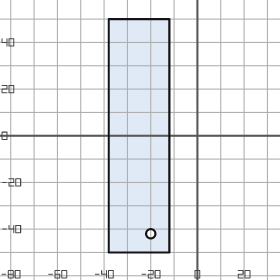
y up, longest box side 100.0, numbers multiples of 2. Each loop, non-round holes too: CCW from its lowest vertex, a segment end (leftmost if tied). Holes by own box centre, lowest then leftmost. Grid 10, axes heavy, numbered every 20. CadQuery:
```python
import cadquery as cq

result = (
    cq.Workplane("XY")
    .moveTo(-38.0, -50.0)
    .lineTo(-12.0, -50.0)
    .lineTo(-12.0, 50.0)
    .lineTo(-38.0, 50.0)
    .close()
    .moveTo(-20.0, -42.0)
    .circle(2.0)
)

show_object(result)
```